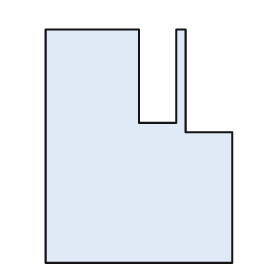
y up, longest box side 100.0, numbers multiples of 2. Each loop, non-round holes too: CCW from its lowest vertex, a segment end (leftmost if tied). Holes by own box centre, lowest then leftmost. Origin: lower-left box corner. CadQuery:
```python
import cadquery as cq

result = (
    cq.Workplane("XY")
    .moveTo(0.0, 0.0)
    .lineTo(80.0, 0.0)
    .lineTo(80.0, 56.0)
    .lineTo(60.0, 56.0)
    .lineTo(60.0, 100.0)
    .lineTo(56.0, 100.0)
    .lineTo(56.0, 60.0)
    .lineTo(40.0, 60.0)
    .lineTo(40.0, 100.0)
    .lineTo(0.0, 100.0)
    .close()
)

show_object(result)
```